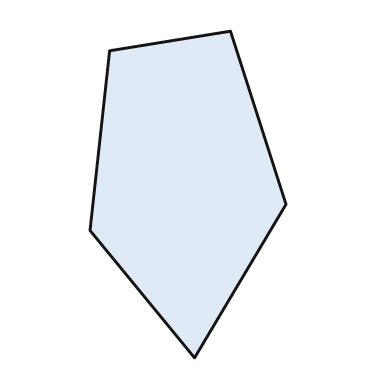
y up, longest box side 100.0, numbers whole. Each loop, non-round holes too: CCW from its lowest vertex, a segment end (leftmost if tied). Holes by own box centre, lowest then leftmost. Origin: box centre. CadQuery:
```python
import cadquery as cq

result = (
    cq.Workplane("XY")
    .moveTo(2.0, -50.0)
    .lineTo(30.0, -3.0)
    .lineTo(13.0, 50.0)
    .lineTo(-24.0, 44.0)
    .lineTo(-30.0, -11.0)
    .close()
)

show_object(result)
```